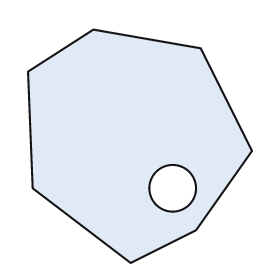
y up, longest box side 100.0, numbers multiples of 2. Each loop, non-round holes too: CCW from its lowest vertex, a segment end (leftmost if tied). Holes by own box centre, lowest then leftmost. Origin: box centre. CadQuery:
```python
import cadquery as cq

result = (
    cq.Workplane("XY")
    .moveTo(-4.0, -50.0)
    .lineTo(24.0, -36.0)
    .lineTo(48.0, -2.0)
    .lineTo(26.0, 42.0)
    .lineTo(-20.0, 50.0)
    .lineTo(-48.0, 32.0)
    .lineTo(-46.0, -18.0)
    .close()
    .moveTo(14.0, -18.0)
    .circle(10.0)
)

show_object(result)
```